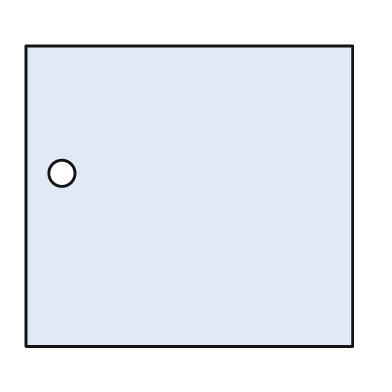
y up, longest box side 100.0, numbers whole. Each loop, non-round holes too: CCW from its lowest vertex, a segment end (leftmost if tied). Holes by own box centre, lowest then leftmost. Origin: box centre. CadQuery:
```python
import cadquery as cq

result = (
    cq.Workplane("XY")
    .moveTo(-50.0, -46.0)
    .lineTo(50.0, -46.0)
    .lineTo(50.0, 46.0)
    .lineTo(-50.0, 46.0)
    .close()
    .moveTo(-39.0, 7.0)
    .circle(4.0)
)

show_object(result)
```